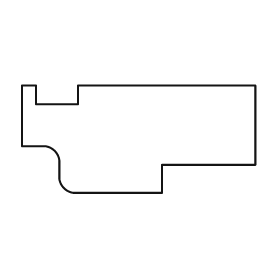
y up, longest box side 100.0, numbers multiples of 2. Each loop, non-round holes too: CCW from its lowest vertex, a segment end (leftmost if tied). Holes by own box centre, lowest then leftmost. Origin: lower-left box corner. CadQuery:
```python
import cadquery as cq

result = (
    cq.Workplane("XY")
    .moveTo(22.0, 0.0)
    .lineTo(60.0, 0.0)
    .lineTo(60.0, 12.0)
    .lineTo(100.0, 12.0)
    .lineTo(100.0, 46.0)
    .lineTo(24.0, 46.0)
    .lineTo(24.0, 38.0)
    .lineTo(6.0, 38.0)
    .lineTo(6.0, 46.0)
    .lineTo(0.0, 46.0)
    .lineTo(0.0, 20.0)
    .lineTo(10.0, 20.0)
    .threePointArc((14.0, 18.0), (16.0, 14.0))
    .lineTo(16.0, 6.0)
    .threePointArc((18.0, 2.0), (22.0, 0.0))
    .close()
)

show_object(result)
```